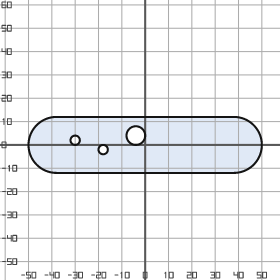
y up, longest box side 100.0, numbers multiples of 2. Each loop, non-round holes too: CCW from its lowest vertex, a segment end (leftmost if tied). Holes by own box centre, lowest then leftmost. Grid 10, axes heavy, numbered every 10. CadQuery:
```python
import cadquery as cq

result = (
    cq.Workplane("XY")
    .moveTo(-38.0, -12.0)
    .lineTo(38.0, -12.0)
    .threePointArc((50.0, 0.0), (38.0, 12.0))
    .lineTo(-38.0, 12.0)
    .threePointArc((-50.0, 0.0), (-38.0, -12.0))
    .close()
    .moveTo(-18.0, -2.0)
    .circle(2.0)
    .moveTo(-30.0, 2.0)
    .circle(2.0)
    .moveTo(-4.0, 4.0)
    .circle(4.0)
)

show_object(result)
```